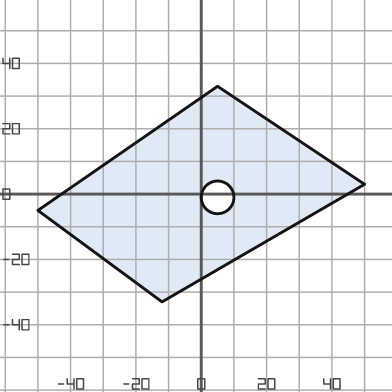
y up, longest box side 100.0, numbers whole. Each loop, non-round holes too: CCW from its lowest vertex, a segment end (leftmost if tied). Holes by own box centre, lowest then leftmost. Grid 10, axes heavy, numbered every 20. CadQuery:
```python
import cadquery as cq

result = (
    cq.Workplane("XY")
    .moveTo(-12.0, -33.0)
    .lineTo(50.0, 3.0)
    .lineTo(5.0, 33.0)
    .lineTo(-50.0, -5.0)
    .close()
    .moveTo(5.0, -1.0)
    .circle(5.0)
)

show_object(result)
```